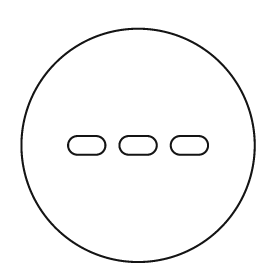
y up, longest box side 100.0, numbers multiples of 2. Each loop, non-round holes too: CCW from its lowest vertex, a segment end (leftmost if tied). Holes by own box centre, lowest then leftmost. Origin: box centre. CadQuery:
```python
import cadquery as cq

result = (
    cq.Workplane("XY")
    .moveTo(0.0, 0.0)
    .circle(50.0)
    .moveTo(-26.0, -4.0)
    .lineTo(-18.0, -4.0)
    .threePointArc((-14.0, 0.0), (-18.0, 4.0))
    .lineTo(-26.0, 4.0)
    .threePointArc((-30.0, 0.0), (-26.0, -4.0))
    .close()
    .moveTo(-4.0, -4.0)
    .lineTo(4.0, -4.0)
    .threePointArc((8.0, 0.0), (4.0, 4.0))
    .lineTo(-4.0, 4.0)
    .threePointArc((-8.0, 0.0), (-4.0, -4.0))
    .close()
    .moveTo(18.0, -4.0)
    .lineTo(26.0, -4.0)
    .threePointArc((30.0, 0.0), (26.0, 4.0))
    .lineTo(18.0, 4.0)
    .threePointArc((14.0, 0.0), (18.0, -4.0))
    .close()
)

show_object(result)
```